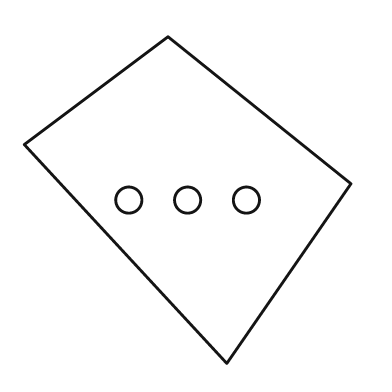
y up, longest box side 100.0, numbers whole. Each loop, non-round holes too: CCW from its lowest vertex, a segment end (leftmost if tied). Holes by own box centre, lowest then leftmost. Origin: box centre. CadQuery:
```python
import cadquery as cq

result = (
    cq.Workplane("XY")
    .moveTo(12.0, -50.0)
    .lineTo(50.0, 5.0)
    .lineTo(-6.0, 50.0)
    .lineTo(-50.0, 17.0)
    .close()
    .moveTo(-18.0, 0.0)
    .circle(4.0)
    .moveTo(0.0, 0.0)
    .circle(4.0)
    .moveTo(18.0, 0.0)
    .circle(4.0)
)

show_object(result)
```